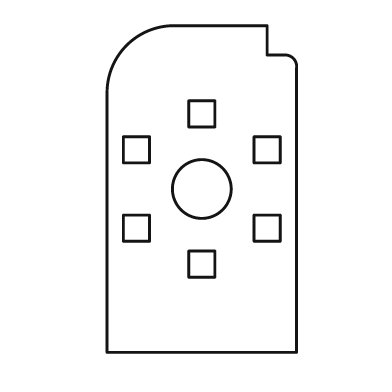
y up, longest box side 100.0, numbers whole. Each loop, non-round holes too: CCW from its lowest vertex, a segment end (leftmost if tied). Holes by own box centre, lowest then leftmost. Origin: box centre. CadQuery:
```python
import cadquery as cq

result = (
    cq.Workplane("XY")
    .moveTo(-29.0, -50.0)
    .lineTo(29.0, -50.0)
    .lineTo(29.0, 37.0)
    .threePointArc((28.0, 40.0), (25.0, 41.0))
    .lineTo(20.0, 41.0)
    .lineTo(20.0, 50.0)
    .lineTo(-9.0, 50.0)
    .threePointArc((-23.0, 44.0), (-29.0, 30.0))
    .close()
    .moveTo(-4.0, -27.0)
    .lineTo(4.0, -27.0)
    .lineTo(4.0, -19.0)
    .lineTo(-4.0, -19.0)
    .close()
    .moveTo(-24.0, -16.0)
    .lineTo(-16.0, -16.0)
    .lineTo(-16.0, -8.0)
    .lineTo(-24.0, -8.0)
    .close()
    .moveTo(16.0, -16.0)
    .lineTo(24.0, -16.0)
    .lineTo(24.0, -8.0)
    .lineTo(16.0, -8.0)
    .close()
    .moveTo(0.0, 0.0)
    .circle(9.0)
    .moveTo(-24.0, 8.0)
    .lineTo(-16.0, 8.0)
    .lineTo(-16.0, 16.0)
    .lineTo(-24.0, 16.0)
    .close()
    .moveTo(16.0, 8.0)
    .lineTo(24.0, 8.0)
    .lineTo(24.0, 16.0)
    .lineTo(16.0, 16.0)
    .close()
    .moveTo(-4.0, 19.0)
    .lineTo(4.0, 19.0)
    .lineTo(4.0, 27.0)
    .lineTo(-4.0, 27.0)
    .close()
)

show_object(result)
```